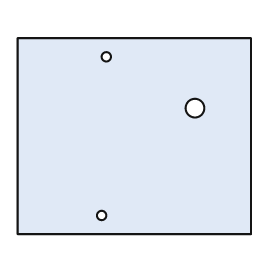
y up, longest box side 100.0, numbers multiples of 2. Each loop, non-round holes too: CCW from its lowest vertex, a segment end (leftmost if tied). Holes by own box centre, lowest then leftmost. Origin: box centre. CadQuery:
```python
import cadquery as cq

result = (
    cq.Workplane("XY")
    .moveTo(-50.0, -42.0)
    .lineTo(50.0, -42.0)
    .lineTo(50.0, 42.0)
    .lineTo(-50.0, 42.0)
    .close()
    .moveTo(-14.0, -34.0)
    .circle(2.0)
    .moveTo(26.0, 12.0)
    .circle(4.0)
    .moveTo(-12.0, 34.0)
    .circle(2.0)
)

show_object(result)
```